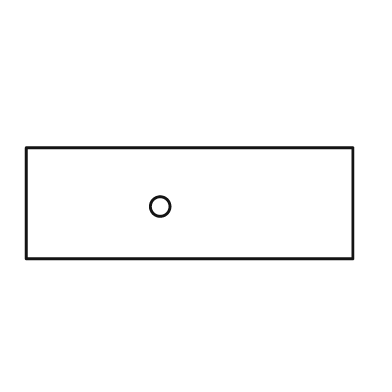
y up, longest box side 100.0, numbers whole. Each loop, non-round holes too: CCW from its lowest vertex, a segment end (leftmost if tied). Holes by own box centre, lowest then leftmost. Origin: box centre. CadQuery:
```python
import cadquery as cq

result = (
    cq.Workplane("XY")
    .moveTo(-50.0, -17.0)
    .lineTo(50.0, -17.0)
    .lineTo(50.0, 17.0)
    .lineTo(-50.0, 17.0)
    .close()
    .moveTo(-9.0, -1.0)
    .circle(3.0)
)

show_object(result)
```